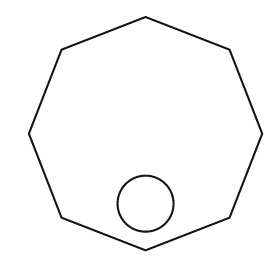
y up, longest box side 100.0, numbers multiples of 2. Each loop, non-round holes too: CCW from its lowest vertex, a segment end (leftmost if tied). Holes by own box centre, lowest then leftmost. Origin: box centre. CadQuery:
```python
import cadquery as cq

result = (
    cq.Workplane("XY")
    .moveTo(0.0, -50.0)
    .lineTo(36.0, -36.0)
    .lineTo(50.0, 0.0)
    .lineTo(36.0, 36.0)
    .lineTo(0.0, 50.0)
    .lineTo(-36.0, 36.0)
    .lineTo(-50.0, 0.0)
    .lineTo(-36.0, -36.0)
    .close()
    .moveTo(0.0, -30.0)
    .circle(12.0)
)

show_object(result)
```